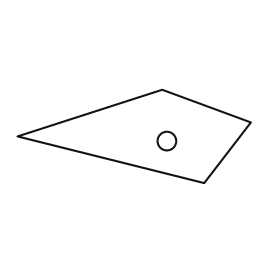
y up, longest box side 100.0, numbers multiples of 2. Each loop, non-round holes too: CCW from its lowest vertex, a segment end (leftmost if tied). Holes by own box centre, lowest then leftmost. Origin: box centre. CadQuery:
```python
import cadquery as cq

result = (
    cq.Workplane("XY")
    .moveTo(30.0, -20.0)
    .lineTo(50.0, 6.0)
    .lineTo(12.0, 20.0)
    .lineTo(-50.0, 0.0)
    .close()
    .moveTo(14.0, -2.0)
    .circle(4.0)
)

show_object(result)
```